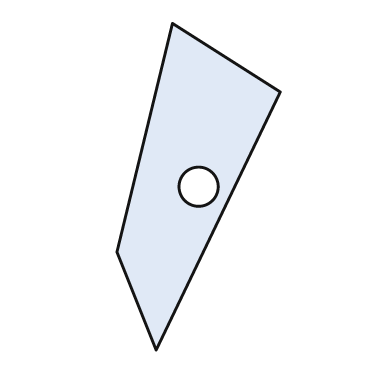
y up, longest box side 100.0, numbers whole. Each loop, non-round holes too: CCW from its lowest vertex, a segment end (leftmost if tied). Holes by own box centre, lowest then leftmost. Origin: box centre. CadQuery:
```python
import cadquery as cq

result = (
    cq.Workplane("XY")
    .moveTo(-13.0, -50.0)
    .lineTo(25.0, 29.0)
    .lineTo(-8.0, 50.0)
    .lineTo(-25.0, -20.0)
    .close()
    .moveTo(0.0, 0.0)
    .circle(6.0)
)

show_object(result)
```